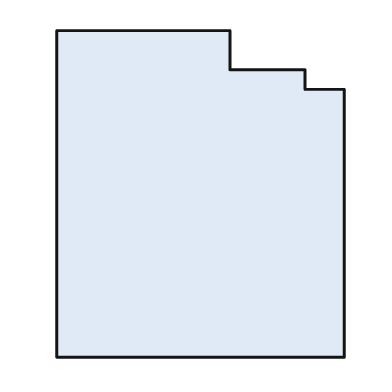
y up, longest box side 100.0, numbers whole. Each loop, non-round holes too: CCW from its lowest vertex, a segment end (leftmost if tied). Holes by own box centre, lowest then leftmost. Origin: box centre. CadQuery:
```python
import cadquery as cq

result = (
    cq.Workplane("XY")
    .moveTo(-44.0, -50.0)
    .lineTo(44.0, -50.0)
    .lineTo(44.0, 32.0)
    .lineTo(32.0, 32.0)
    .lineTo(32.0, 38.0)
    .lineTo(9.0, 38.0)
    .lineTo(9.0, 50.0)
    .lineTo(-44.0, 50.0)
    .close()
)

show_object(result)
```